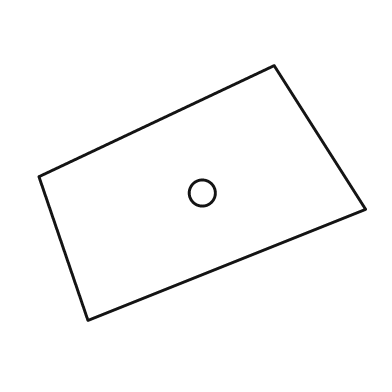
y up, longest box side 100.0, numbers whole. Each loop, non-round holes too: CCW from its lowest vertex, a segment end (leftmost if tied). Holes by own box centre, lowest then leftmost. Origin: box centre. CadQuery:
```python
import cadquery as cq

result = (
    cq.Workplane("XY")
    .moveTo(-35.0, -39.0)
    .lineTo(50.0, -5.0)
    .lineTo(22.0, 39.0)
    .lineTo(-50.0, 5.0)
    .close()
    .moveTo(0.0, 0.0)
    .circle(4.0)
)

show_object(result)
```